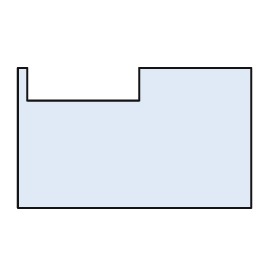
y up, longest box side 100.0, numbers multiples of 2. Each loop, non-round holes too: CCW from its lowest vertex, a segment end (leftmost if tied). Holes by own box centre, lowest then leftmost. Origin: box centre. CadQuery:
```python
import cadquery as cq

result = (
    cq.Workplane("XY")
    .moveTo(-50.0, -30.0)
    .lineTo(50.0, -30.0)
    .lineTo(50.0, 30.0)
    .lineTo(2.0, 30.0)
    .lineTo(2.0, 16.0)
    .lineTo(-46.0, 16.0)
    .lineTo(-46.0, 30.0)
    .lineTo(-50.0, 30.0)
    .close()
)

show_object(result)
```